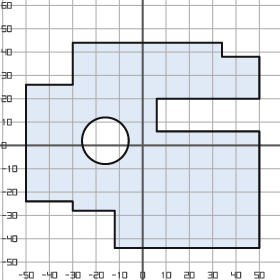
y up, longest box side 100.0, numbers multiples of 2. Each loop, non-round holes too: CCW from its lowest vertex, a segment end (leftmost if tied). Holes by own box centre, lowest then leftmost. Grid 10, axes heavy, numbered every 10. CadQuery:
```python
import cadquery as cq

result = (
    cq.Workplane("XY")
    .moveTo(-12.0, -44.0)
    .lineTo(50.0, -44.0)
    .lineTo(50.0, 6.0)
    .lineTo(6.0, 6.0)
    .lineTo(6.0, 20.0)
    .lineTo(50.0, 20.0)
    .lineTo(50.0, 38.0)
    .lineTo(34.0, 38.0)
    .lineTo(34.0, 44.0)
    .lineTo(-30.0, 44.0)
    .lineTo(-30.0, 26.0)
    .lineTo(-50.0, 26.0)
    .lineTo(-50.0, -24.0)
    .lineTo(-30.0, -24.0)
    .lineTo(-30.0, -28.0)
    .lineTo(-12.0, -28.0)
    .close()
    .moveTo(-16.0, 2.0)
    .circle(10.0)
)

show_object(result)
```